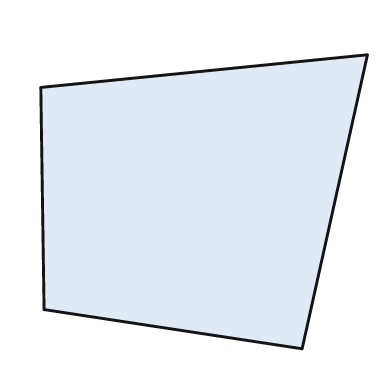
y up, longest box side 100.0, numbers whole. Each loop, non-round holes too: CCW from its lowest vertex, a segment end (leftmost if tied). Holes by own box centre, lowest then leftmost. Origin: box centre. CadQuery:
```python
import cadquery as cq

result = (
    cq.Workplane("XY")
    .moveTo(30.0, -45.0)
    .lineTo(50.0, 45.0)
    .lineTo(-50.0, 35.0)
    .lineTo(-49.0, -33.0)
    .close()
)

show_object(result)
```